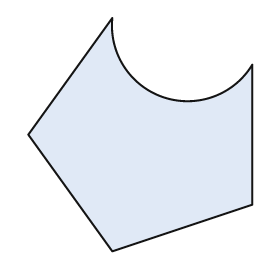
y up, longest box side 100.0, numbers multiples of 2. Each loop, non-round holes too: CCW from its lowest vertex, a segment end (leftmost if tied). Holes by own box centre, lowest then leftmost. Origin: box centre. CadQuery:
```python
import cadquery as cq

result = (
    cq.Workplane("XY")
    .moveTo(-12.0, -50.0)
    .lineTo(48.0, -30.0)
    .lineTo(48.0, 30.0)
    .threePointArc((10.0, 16.0), (-12.0, 50.0))
    .lineTo(-48.0, 0.0)
    .close()
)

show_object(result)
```